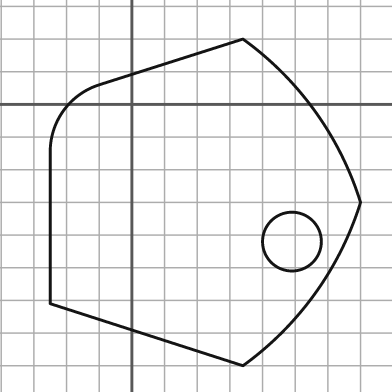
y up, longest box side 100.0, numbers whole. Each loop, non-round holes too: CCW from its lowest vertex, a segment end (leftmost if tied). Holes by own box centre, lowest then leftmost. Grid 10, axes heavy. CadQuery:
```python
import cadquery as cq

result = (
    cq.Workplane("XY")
    .moveTo(34.0, -80.0)
    .threePointArc((56.0, -58.0), (70.0, -30.0))
    .threePointArc((56.0, -2.0), (34.0, 20.0))
    .lineTo(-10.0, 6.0)
    .threePointArc((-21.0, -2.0), (-25.0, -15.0))
    .lineTo(-25.0, -61.0)
    .close()
    .moveTo(49.0, -42.0)
    .circle(9.0)
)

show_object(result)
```